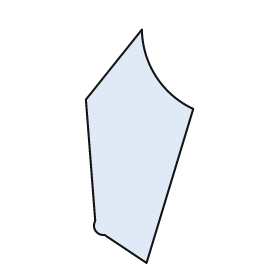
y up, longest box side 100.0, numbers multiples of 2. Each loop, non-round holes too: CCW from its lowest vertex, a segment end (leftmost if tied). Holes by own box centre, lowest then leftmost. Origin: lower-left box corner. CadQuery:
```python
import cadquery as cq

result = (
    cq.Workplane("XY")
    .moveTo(26.0, 0.0)
    .lineTo(46.0, 66.0)
    .threePointArc((30.0, 80.0), (24.0, 100.0))
    .lineTo(0.0, 70.0)
    .lineTo(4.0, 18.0)
    .threePointArc((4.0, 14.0), (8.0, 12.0))
    .close()
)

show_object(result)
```